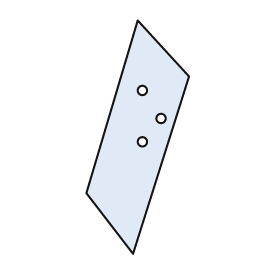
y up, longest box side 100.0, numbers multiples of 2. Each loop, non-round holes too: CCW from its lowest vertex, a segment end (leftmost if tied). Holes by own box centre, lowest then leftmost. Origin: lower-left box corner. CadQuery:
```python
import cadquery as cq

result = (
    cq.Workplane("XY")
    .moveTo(20.0, 0.0)
    .lineTo(44.0, 76.0)
    .lineTo(22.0, 100.0)
    .lineTo(0.0, 26.0)
    .close()
    .moveTo(24.0, 48.0)
    .circle(2.0)
    .moveTo(32.0, 58.0)
    .circle(2.0)
    .moveTo(24.0, 70.0)
    .circle(2.0)
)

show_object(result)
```